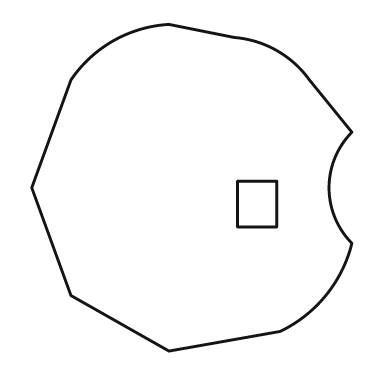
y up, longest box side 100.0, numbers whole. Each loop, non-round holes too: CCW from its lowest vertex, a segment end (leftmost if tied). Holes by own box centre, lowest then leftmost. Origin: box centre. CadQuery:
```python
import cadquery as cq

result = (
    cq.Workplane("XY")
    .moveTo(-7.0, -50.0)
    .lineTo(27.0, -44.0)
    .threePointArc((41.0, -33.0), (49.0, -17.0))
    .threePointArc((42.0, 0.0), (49.0, 17.0))
    .lineTo(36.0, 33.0)
    .threePointArc((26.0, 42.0), (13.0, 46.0))
    .lineTo(-7.0, 50.0)
    .threePointArc((-24.0, 45.0), (-37.0, 33.0))
    .lineTo(-49.0, 0.0)
    .lineTo(-37.0, -33.0)
    .close()
    .moveTo(14.0, -12.0)
    .lineTo(26.0, -12.0)
    .lineTo(26.0, 2.0)
    .lineTo(14.0, 2.0)
    .close()
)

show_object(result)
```